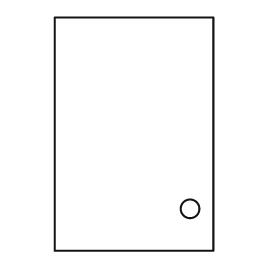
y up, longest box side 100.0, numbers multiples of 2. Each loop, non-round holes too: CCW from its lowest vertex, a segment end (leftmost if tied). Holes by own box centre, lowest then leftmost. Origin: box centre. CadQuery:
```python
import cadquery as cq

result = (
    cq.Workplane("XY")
    .moveTo(-34.0, -50.0)
    .lineTo(34.0, -50.0)
    .lineTo(34.0, 50.0)
    .lineTo(-34.0, 50.0)
    .close()
    .moveTo(24.0, -32.0)
    .circle(4.0)
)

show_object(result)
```